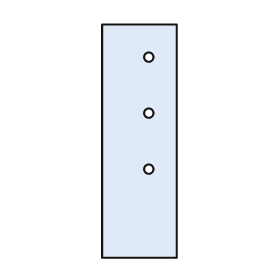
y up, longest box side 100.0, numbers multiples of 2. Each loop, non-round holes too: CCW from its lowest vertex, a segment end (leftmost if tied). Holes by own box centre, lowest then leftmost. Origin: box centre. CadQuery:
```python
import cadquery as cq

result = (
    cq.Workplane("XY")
    .moveTo(-16.0, -50.0)
    .lineTo(16.0, -50.0)
    .lineTo(16.0, 50.0)
    .lineTo(-16.0, 50.0)
    .close()
    .moveTo(4.0, -12.0)
    .circle(2.0)
    .moveTo(4.0, 12.0)
    .circle(2.0)
    .moveTo(4.0, 36.0)
    .circle(2.0)
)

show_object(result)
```